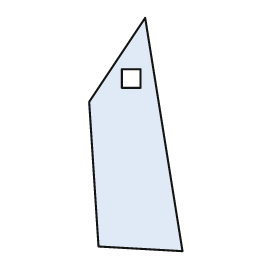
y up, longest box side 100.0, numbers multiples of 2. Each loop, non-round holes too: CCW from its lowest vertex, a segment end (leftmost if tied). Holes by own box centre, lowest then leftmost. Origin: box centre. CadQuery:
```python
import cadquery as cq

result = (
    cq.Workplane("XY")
    .moveTo(20.0, -50.0)
    .lineTo(4.0, 50.0)
    .lineTo(-20.0, 14.0)
    .lineTo(-16.0, -48.0)
    .close()
    .moveTo(-6.0, 20.0)
    .lineTo(2.0, 20.0)
    .lineTo(2.0, 28.0)
    .lineTo(-6.0, 28.0)
    .close()
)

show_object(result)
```